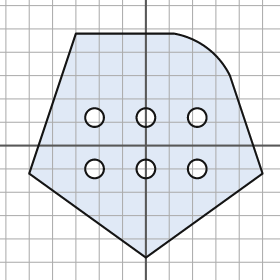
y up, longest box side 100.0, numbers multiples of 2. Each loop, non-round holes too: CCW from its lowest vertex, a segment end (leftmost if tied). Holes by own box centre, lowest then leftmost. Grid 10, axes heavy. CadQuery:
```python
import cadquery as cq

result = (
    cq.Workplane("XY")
    .moveTo(0.0, -48.0)
    .lineTo(50.0, -12.0)
    .lineTo(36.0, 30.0)
    .threePointArc((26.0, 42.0), (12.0, 48.0))
    .lineTo(-30.0, 48.0)
    .lineTo(-50.0, -12.0)
    .close()
    .moveTo(-22.0, -10.0)
    .circle(4.0)
    .moveTo(0.0, -10.0)
    .circle(4.0)
    .moveTo(22.0, -10.0)
    .circle(4.0)
    .moveTo(-22.0, 12.0)
    .circle(4.0)
    .moveTo(0.0, 12.0)
    .circle(4.0)
    .moveTo(22.0, 12.0)
    .circle(4.0)
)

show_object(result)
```